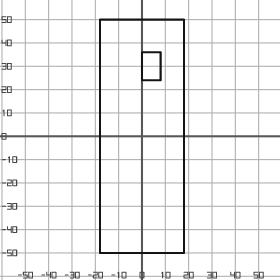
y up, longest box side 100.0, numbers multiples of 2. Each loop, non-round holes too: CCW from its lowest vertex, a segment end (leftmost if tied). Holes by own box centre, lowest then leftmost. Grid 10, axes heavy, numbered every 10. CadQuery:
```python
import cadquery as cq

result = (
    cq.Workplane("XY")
    .moveTo(-18.0, -50.0)
    .lineTo(18.0, -50.0)
    .lineTo(18.0, 50.0)
    .lineTo(-18.0, 50.0)
    .close()
    .moveTo(0.0, 24.0)
    .lineTo(8.0, 24.0)
    .lineTo(8.0, 36.0)
    .lineTo(0.0, 36.0)
    .close()
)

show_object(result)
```